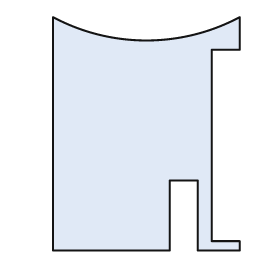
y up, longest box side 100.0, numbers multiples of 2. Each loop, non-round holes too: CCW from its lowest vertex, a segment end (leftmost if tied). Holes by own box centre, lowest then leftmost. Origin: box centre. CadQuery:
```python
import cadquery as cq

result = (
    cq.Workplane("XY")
    .moveTo(-40.0, -50.0)
    .lineTo(10.0, -50.0)
    .lineTo(10.0, -20.0)
    .lineTo(22.0, -20.0)
    .lineTo(22.0, -50.0)
    .lineTo(40.0, -50.0)
    .lineTo(40.0, -46.0)
    .lineTo(28.0, -46.0)
    .lineTo(28.0, 36.0)
    .lineTo(40.0, 36.0)
    .lineTo(40.0, 50.0)
    .threePointArc((0.0, 40.0), (-40.0, 50.0))
    .close()
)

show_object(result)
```